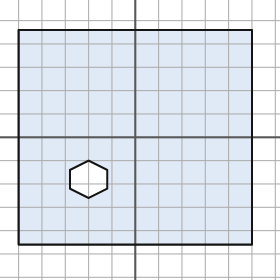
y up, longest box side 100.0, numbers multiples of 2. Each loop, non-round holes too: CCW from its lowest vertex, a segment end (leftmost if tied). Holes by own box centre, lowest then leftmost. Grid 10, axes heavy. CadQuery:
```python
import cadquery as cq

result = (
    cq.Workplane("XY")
    .moveTo(-50.0, -46.0)
    .lineTo(50.0, -46.0)
    .lineTo(50.0, 46.0)
    .lineTo(-50.0, 46.0)
    .close()
    .moveTo(-20.0, -26.0)
    .lineTo(-12.0, -22.0)
    .lineTo(-12.0, -14.0)
    .lineTo(-20.0, -10.0)
    .lineTo(-28.0, -14.0)
    .lineTo(-28.0, -22.0)
    .close()
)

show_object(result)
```